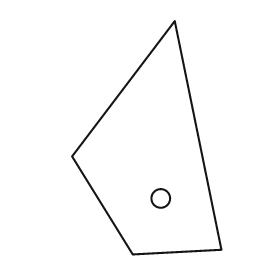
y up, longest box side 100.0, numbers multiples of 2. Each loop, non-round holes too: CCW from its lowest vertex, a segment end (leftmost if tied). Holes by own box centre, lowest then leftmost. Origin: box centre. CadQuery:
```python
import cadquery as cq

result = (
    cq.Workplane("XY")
    .moveTo(-6.0, -50.0)
    .lineTo(32.0, -48.0)
    .lineTo(12.0, 50.0)
    .lineTo(-32.0, -8.0)
    .close()
    .moveTo(6.0, -26.0)
    .circle(4.0)
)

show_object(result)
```